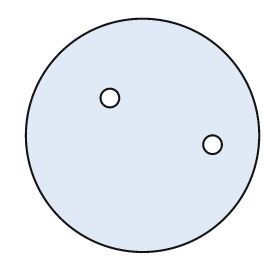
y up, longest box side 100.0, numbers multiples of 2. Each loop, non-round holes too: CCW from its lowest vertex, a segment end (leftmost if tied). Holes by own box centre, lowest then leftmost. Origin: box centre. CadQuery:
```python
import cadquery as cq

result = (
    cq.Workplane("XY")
    .moveTo(0.0, 0.0)
    .circle(50.0)
    .moveTo(30.0, -4.0)
    .circle(4.0)
    .moveTo(-14.0, 16.0)
    .circle(4.0)
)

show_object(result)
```